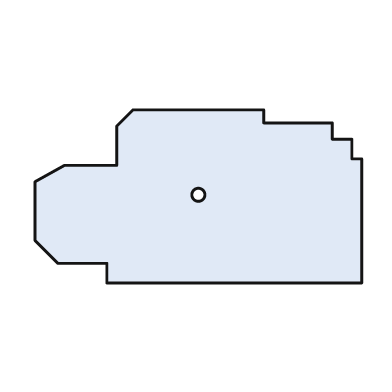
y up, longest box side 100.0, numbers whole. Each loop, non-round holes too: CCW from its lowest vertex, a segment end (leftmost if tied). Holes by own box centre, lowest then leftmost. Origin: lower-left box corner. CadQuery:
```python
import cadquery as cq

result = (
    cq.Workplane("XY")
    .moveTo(22.0, 0.0)
    .lineTo(100.0, 0.0)
    .lineTo(100.0, 38.0)
    .lineTo(97.0, 38.0)
    .lineTo(97.0, 44.0)
    .lineTo(91.0, 44.0)
    .lineTo(91.0, 49.0)
    .lineTo(70.0, 49.0)
    .lineTo(70.0, 53.0)
    .lineTo(30.0, 53.0)
    .lineTo(25.0, 48.0)
    .lineTo(25.0, 36.0)
    .lineTo(9.0, 36.0)
    .lineTo(0.0, 31.0)
    .lineTo(0.0, 13.0)
    .lineTo(7.0, 6.0)
    .lineTo(22.0, 6.0)
    .close()
    .moveTo(50.0, 27.0)
    .circle(2.0)
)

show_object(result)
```